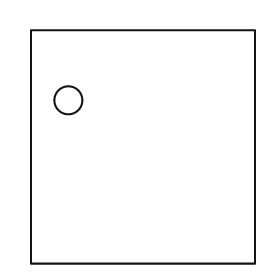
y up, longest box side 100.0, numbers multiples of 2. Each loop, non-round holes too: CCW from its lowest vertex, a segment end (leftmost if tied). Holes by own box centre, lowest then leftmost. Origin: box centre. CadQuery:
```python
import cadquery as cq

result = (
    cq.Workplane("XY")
    .moveTo(-48.0, -50.0)
    .lineTo(48.0, -50.0)
    .lineTo(48.0, 50.0)
    .lineTo(-48.0, 50.0)
    .close()
    .moveTo(-32.0, 20.0)
    .circle(6.0)
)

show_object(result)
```